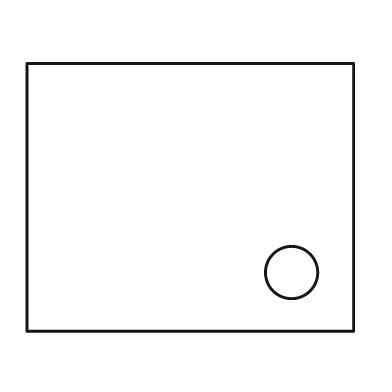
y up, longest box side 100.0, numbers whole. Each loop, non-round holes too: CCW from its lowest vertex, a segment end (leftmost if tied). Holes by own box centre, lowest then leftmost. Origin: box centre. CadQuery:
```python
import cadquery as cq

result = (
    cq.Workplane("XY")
    .moveTo(-50.0, -41.0)
    .lineTo(50.0, -41.0)
    .lineTo(50.0, 41.0)
    .lineTo(-50.0, 41.0)
    .close()
    .moveTo(31.0, -23.0)
    .circle(8.0)
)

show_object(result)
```